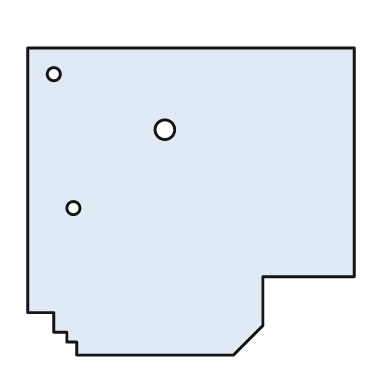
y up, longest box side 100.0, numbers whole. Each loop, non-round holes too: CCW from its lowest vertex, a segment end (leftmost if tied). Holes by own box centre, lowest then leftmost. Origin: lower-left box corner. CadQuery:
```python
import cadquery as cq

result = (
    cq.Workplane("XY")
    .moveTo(15.0, 0.0)
    .lineTo(63.0, 0.0)
    .lineTo(72.0, 9.0)
    .lineTo(72.0, 24.0)
    .lineTo(100.0, 24.0)
    .lineTo(100.0, 94.0)
    .lineTo(0.0, 94.0)
    .lineTo(0.0, 13.0)
    .lineTo(8.0, 13.0)
    .lineTo(8.0, 7.0)
    .lineTo(12.0, 7.0)
    .lineTo(12.0, 4.0)
    .lineTo(15.0, 4.0)
    .close()
    .moveTo(14.0, 45.0)
    .circle(2.0)
    .moveTo(42.0, 69.0)
    .circle(3.0)
    .moveTo(8.0, 86.0)
    .circle(2.0)
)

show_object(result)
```